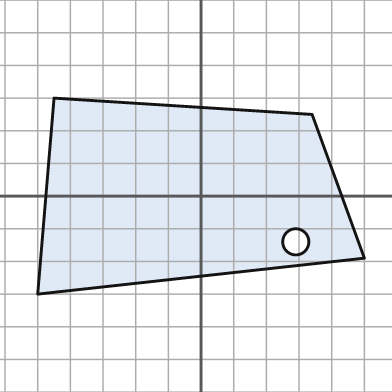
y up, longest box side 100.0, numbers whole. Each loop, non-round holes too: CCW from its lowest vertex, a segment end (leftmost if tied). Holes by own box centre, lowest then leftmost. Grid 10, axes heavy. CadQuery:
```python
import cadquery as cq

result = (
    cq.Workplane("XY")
    .moveTo(-50.0, -30.0)
    .lineTo(50.0, -19.0)
    .lineTo(34.0, 25.0)
    .lineTo(-45.0, 30.0)
    .close()
    .moveTo(29.0, -14.0)
    .circle(4.0)
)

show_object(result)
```